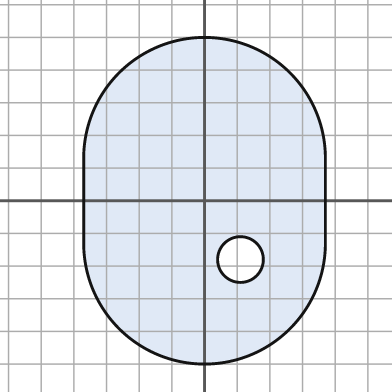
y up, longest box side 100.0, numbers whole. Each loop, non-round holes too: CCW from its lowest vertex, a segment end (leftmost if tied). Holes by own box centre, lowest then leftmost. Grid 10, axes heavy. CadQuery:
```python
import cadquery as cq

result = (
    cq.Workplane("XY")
    .moveTo(-37.0, -13.0)
    .threePointArc((0.0, -50.0), (37.0, -13.0))
    .lineTo(37.0, 13.0)
    .threePointArc((0.0, 50.0), (-37.0, 13.0))
    .close()
    .moveTo(11.0, -18.0)
    .circle(7.0)
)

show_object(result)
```